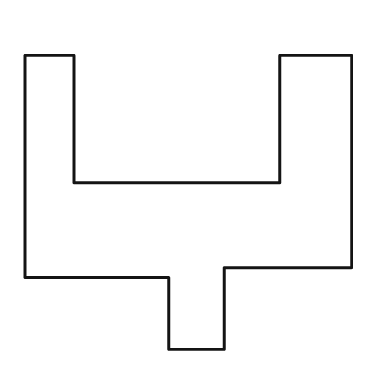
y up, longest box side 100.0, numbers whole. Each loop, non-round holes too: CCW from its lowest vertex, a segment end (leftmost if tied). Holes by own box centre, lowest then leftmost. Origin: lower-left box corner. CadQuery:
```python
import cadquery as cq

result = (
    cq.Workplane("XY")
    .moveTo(44.0, 0.0)
    .lineTo(61.0, 0.0)
    .lineTo(61.0, 25.0)
    .lineTo(100.0, 25.0)
    .lineTo(100.0, 90.0)
    .lineTo(78.0, 90.0)
    .lineTo(78.0, 51.0)
    .lineTo(15.0, 51.0)
    .lineTo(15.0, 90.0)
    .lineTo(0.0, 90.0)
    .lineTo(0.0, 22.0)
    .lineTo(44.0, 22.0)
    .close()
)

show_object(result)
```